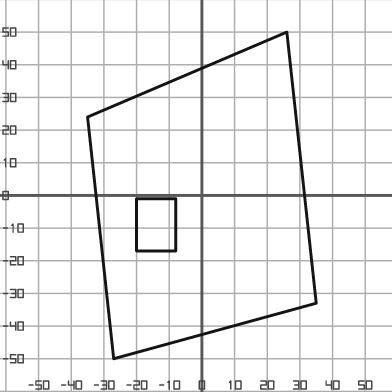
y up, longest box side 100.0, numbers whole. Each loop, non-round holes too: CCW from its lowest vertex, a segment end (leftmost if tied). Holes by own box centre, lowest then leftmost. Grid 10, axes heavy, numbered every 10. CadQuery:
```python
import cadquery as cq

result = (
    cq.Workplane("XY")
    .moveTo(-27.0, -50.0)
    .lineTo(35.0, -33.0)
    .lineTo(26.0, 50.0)
    .lineTo(-35.0, 24.0)
    .close()
    .moveTo(-20.0, -17.0)
    .lineTo(-8.0, -17.0)
    .lineTo(-8.0, -1.0)
    .lineTo(-20.0, -1.0)
    .close()
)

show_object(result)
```